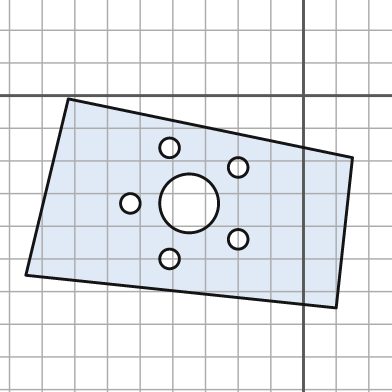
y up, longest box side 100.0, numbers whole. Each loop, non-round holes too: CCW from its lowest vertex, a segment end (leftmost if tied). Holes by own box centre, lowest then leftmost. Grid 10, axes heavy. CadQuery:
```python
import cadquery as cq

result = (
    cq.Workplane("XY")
    .moveTo(10.0, -65.0)
    .lineTo(15.0, -19.0)
    .lineTo(-72.0, -1.0)
    .lineTo(-85.0, -55.0)
    .close()
    .moveTo(-41.0, -50.0)
    .circle(3.0)
    .moveTo(-20.0, -44.0)
    .circle(3.0)
    .moveTo(-53.0, -33.0)
    .circle(3.0)
    .moveTo(-35.0, -33.0)
    .circle(9.0)
    .moveTo(-20.0, -22.0)
    .circle(3.0)
    .moveTo(-41.0, -16.0)
    .circle(3.0)
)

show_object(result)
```